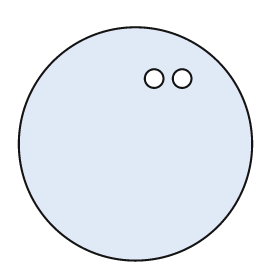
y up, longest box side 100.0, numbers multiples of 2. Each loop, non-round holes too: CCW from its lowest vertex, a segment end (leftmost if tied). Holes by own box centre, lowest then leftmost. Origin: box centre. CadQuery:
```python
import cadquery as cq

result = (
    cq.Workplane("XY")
    .moveTo(0.0, 0.0)
    .circle(50.0)
    .moveTo(8.0, 28.0)
    .circle(4.0)
    .moveTo(20.0, 28.0)
    .circle(4.0)
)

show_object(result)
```